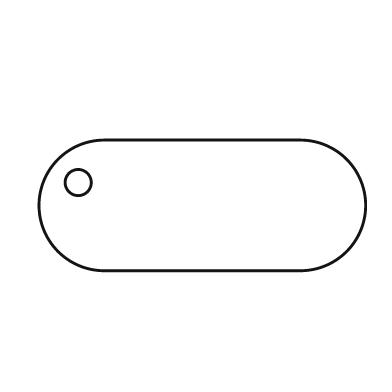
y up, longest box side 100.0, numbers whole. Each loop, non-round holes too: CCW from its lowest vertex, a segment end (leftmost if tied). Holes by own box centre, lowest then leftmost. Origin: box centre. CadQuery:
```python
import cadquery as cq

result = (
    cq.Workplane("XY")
    .moveTo(-30.0, -20.0)
    .lineTo(30.0, -20.0)
    .threePointArc((50.0, 0.0), (30.0, 20.0))
    .lineTo(-30.0, 20.0)
    .threePointArc((-50.0, 0.0), (-30.0, -20.0))
    .close()
    .moveTo(-38.0, 7.0)
    .circle(4.0)
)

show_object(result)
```